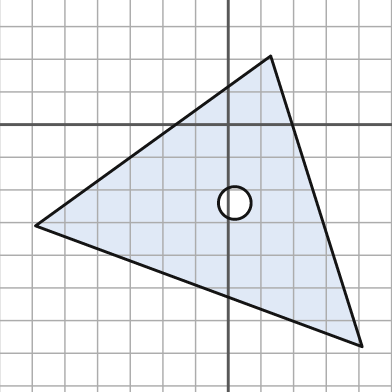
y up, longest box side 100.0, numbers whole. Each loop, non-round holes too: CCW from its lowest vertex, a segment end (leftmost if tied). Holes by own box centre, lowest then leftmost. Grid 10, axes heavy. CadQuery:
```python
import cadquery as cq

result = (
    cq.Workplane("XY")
    .moveTo(41.0, -68.0)
    .lineTo(13.0, 21.0)
    .lineTo(-59.0, -31.0)
    .close()
    .moveTo(2.0, -24.0)
    .circle(5.0)
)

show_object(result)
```